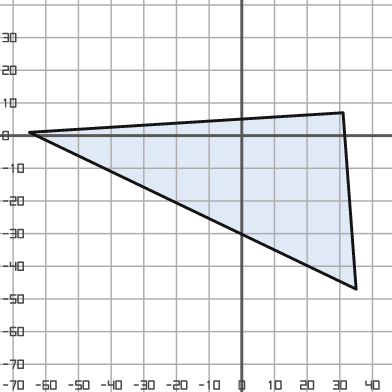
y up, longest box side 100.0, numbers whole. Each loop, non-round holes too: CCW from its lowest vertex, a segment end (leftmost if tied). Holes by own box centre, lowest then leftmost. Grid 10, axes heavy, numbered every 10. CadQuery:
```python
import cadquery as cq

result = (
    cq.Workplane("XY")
    .moveTo(35.0, -47.0)
    .lineTo(31.0, 7.0)
    .lineTo(-65.0, 1.0)
    .close()
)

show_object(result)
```